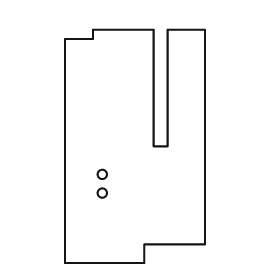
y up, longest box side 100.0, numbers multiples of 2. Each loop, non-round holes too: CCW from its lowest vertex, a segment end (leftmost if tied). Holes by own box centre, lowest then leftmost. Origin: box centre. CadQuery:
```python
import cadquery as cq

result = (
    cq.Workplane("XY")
    .moveTo(-30.0, -50.0)
    .lineTo(4.0, -50.0)
    .lineTo(4.0, -42.0)
    .lineTo(30.0, -42.0)
    .lineTo(30.0, 50.0)
    .lineTo(14.0, 50.0)
    .lineTo(14.0, 0.0)
    .lineTo(8.0, 0.0)
    .lineTo(8.0, 50.0)
    .lineTo(-18.0, 50.0)
    .lineTo(-18.0, 46.0)
    .lineTo(-30.0, 46.0)
    .close()
    .moveTo(-14.0, -20.0)
    .circle(2.0)
    .moveTo(-14.0, -12.0)
    .circle(2.0)
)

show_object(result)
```